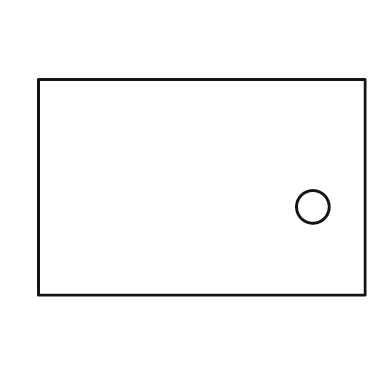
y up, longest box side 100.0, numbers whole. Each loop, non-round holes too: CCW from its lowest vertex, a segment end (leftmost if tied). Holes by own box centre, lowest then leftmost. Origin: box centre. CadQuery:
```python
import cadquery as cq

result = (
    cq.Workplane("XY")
    .moveTo(-50.0, -33.0)
    .lineTo(50.0, -33.0)
    .lineTo(50.0, 33.0)
    .lineTo(-50.0, 33.0)
    .close()
    .moveTo(34.0, -6.0)
    .circle(5.0)
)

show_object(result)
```